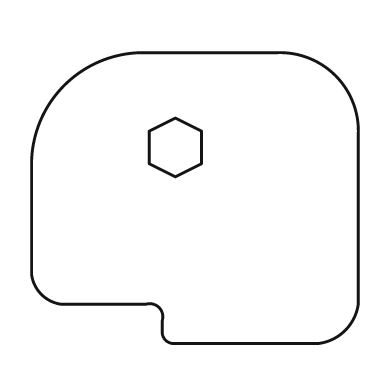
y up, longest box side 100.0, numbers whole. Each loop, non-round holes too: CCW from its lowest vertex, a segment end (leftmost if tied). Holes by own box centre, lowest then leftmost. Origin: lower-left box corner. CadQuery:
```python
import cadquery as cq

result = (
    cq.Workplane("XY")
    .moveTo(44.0, 0.0)
    .lineTo(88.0, 0.0)
    .threePointArc((96.0, 4.0), (100.0, 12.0))
    .lineTo(100.0, 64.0)
    .threePointArc((93.0, 82.0), (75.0, 89.0))
    .lineTo(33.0, 89.0)
    .threePointArc((10.0, 79.0), (0.0, 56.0))
    .lineTo(0.0, 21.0)
    .threePointArc((3.0, 15.0), (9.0, 12.0))
    .lineTo(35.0, 12.0)
    .threePointArc((39.0, 11.0), (40.0, 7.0))
    .lineTo(40.0, 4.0)
    .threePointArc((41.0, 1.0), (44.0, 0.0))
    .close()
    .moveTo(44.0, 51.0)
    .lineTo(52.0, 55.0)
    .lineTo(52.0, 65.0)
    .lineTo(44.0, 69.0)
    .lineTo(36.0, 65.0)
    .lineTo(36.0, 55.0)
    .close()
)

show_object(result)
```